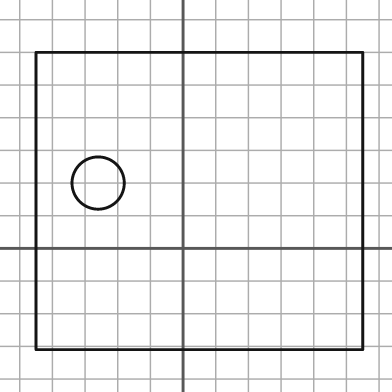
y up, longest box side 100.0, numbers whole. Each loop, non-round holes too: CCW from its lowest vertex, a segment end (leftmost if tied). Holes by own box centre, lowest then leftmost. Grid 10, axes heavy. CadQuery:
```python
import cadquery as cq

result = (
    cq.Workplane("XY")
    .moveTo(-45.0, -31.0)
    .lineTo(55.0, -31.0)
    .lineTo(55.0, 60.0)
    .lineTo(-45.0, 60.0)
    .close()
    .moveTo(-26.0, 20.0)
    .circle(8.0)
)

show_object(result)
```